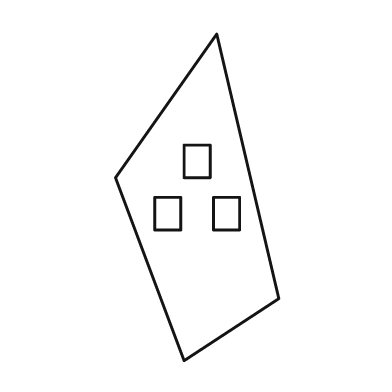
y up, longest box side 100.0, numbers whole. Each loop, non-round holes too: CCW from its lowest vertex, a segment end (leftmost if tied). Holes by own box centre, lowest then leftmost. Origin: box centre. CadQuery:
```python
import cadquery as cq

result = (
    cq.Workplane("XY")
    .moveTo(-4.0, -50.0)
    .lineTo(25.0, -31.0)
    .lineTo(6.0, 50.0)
    .lineTo(-25.0, 6.0)
    .close()
    .moveTo(-13.0, -10.0)
    .lineTo(-5.0, -10.0)
    .lineTo(-5.0, 0.0)
    .lineTo(-13.0, 0.0)
    .close()
    .moveTo(5.0, -10.0)
    .lineTo(13.0, -10.0)
    .lineTo(13.0, 0.0)
    .lineTo(5.0, 0.0)
    .close()
    .moveTo(-4.0, 6.0)
    .lineTo(4.0, 6.0)
    .lineTo(4.0, 16.0)
    .lineTo(-4.0, 16.0)
    .close()
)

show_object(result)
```